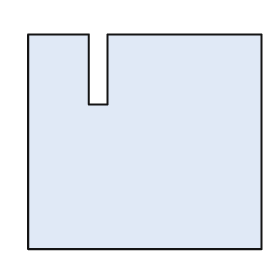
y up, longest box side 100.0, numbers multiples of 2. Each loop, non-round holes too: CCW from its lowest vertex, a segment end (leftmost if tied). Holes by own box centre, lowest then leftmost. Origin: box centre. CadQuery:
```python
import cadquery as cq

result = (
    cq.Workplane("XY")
    .moveTo(-50.0, -46.0)
    .lineTo(50.0, -46.0)
    .lineTo(50.0, 46.0)
    .lineTo(-16.0, 46.0)
    .lineTo(-16.0, 16.0)
    .lineTo(-24.0, 16.0)
    .lineTo(-24.0, 46.0)
    .lineTo(-50.0, 46.0)
    .close()
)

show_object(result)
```